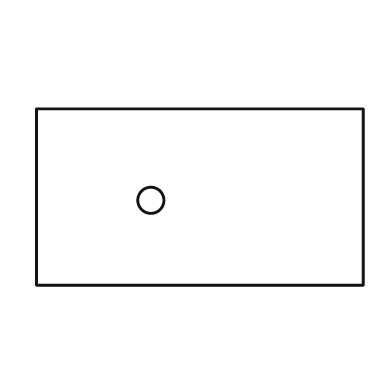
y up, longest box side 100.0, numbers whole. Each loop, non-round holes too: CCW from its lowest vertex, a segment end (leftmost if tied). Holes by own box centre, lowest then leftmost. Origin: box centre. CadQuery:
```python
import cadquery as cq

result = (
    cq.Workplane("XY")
    .moveTo(-50.0, -27.0)
    .lineTo(50.0, -27.0)
    .lineTo(50.0, 27.0)
    .lineTo(-50.0, 27.0)
    .close()
    .moveTo(-15.0, -1.0)
    .circle(4.0)
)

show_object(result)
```